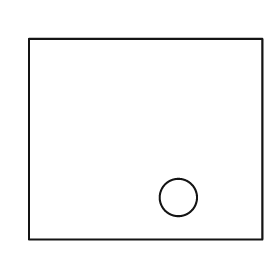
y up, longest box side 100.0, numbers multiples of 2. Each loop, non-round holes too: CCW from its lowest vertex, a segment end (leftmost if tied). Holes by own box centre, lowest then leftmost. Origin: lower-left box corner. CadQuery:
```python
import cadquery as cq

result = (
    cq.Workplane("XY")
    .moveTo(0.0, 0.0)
    .lineTo(100.0, 0.0)
    .lineTo(100.0, 86.0)
    .lineTo(0.0, 86.0)
    .close()
    .moveTo(64.0, 18.0)
    .circle(8.0)
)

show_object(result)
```